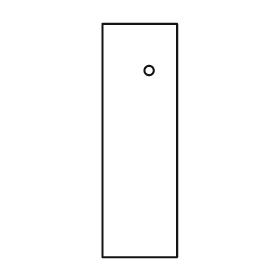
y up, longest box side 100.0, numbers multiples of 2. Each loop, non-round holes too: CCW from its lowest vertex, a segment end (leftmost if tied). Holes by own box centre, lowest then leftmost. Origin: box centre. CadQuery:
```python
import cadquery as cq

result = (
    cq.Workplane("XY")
    .moveTo(-16.0, -50.0)
    .lineTo(16.0, -50.0)
    .lineTo(16.0, 50.0)
    .lineTo(-16.0, 50.0)
    .close()
    .moveTo(4.0, 30.0)
    .circle(2.0)
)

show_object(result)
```